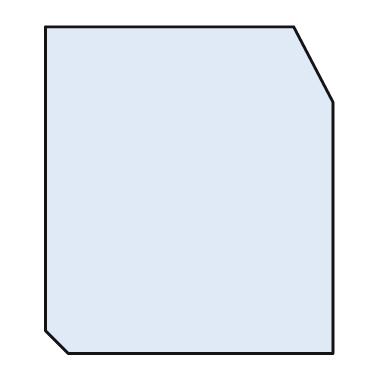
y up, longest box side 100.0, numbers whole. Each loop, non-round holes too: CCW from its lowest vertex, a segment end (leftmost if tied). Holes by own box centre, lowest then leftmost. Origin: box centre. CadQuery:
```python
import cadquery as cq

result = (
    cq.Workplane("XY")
    .moveTo(-37.0, -50.0)
    .lineTo(44.0, -50.0)
    .lineTo(44.0, 27.0)
    .lineTo(32.0, 50.0)
    .lineTo(-44.0, 50.0)
    .lineTo(-44.0, -43.0)
    .close()
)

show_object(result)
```